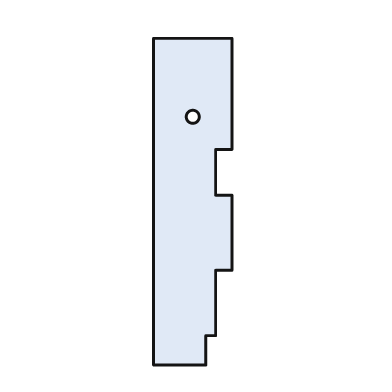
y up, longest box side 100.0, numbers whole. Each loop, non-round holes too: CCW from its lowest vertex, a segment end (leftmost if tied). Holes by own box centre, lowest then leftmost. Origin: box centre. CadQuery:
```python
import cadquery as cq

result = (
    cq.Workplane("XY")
    .moveTo(-12.0, -50.0)
    .lineTo(4.0, -50.0)
    .lineTo(4.0, -41.0)
    .lineTo(7.0, -41.0)
    .lineTo(7.0, -21.0)
    .lineTo(12.0, -21.0)
    .lineTo(12.0, 2.0)
    .lineTo(7.0, 2.0)
    .lineTo(7.0, 16.0)
    .lineTo(12.0, 16.0)
    .lineTo(12.0, 50.0)
    .lineTo(-12.0, 50.0)
    .close()
    .moveTo(0.0, 26.0)
    .circle(2.0)
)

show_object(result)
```